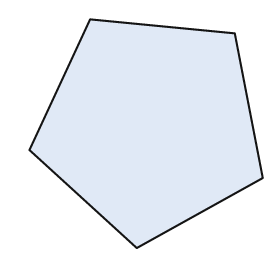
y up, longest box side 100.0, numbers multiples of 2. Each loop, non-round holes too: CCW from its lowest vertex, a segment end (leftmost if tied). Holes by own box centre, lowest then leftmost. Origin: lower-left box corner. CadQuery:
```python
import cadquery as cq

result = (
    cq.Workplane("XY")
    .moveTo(46.0, 0.0)
    .lineTo(100.0, 30.0)
    .lineTo(88.0, 92.0)
    .lineTo(26.0, 98.0)
    .lineTo(0.0, 42.0)
    .close()
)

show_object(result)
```